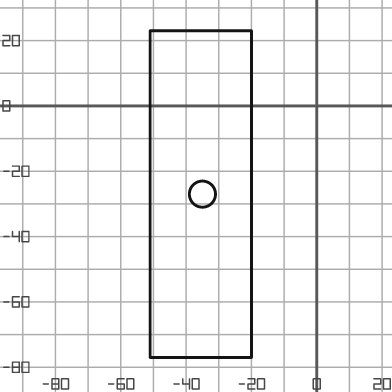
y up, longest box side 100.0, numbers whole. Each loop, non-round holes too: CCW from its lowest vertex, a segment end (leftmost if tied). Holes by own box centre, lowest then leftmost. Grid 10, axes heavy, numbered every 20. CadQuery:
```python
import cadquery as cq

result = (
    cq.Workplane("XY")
    .moveTo(-51.0, -77.0)
    .lineTo(-20.0, -77.0)
    .lineTo(-20.0, 23.0)
    .lineTo(-51.0, 23.0)
    .close()
    .moveTo(-35.0, -27.0)
    .circle(4.0)
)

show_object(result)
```